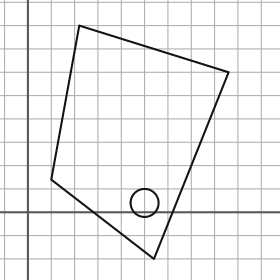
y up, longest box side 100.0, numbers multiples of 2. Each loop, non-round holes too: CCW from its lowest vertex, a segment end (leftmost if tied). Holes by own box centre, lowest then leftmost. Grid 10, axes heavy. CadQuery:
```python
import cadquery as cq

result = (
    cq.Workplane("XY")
    .moveTo(54.0, -20.0)
    .lineTo(86.0, 60.0)
    .lineTo(22.0, 80.0)
    .lineTo(10.0, 14.0)
    .close()
    .moveTo(50.0, 4.0)
    .circle(6.0)
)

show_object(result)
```